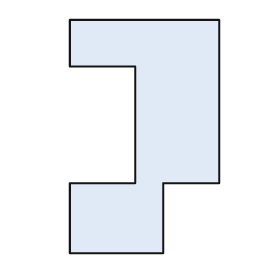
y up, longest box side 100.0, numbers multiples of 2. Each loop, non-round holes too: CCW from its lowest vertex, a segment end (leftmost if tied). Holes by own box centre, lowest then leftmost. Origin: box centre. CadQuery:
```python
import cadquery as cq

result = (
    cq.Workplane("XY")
    .moveTo(-32.0, -50.0)
    .lineTo(8.0, -50.0)
    .lineTo(8.0, -20.0)
    .lineTo(32.0, -20.0)
    .lineTo(32.0, 50.0)
    .lineTo(-32.0, 50.0)
    .lineTo(-32.0, 30.0)
    .lineTo(-4.0, 30.0)
    .lineTo(-4.0, -20.0)
    .lineTo(-32.0, -20.0)
    .close()
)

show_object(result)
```